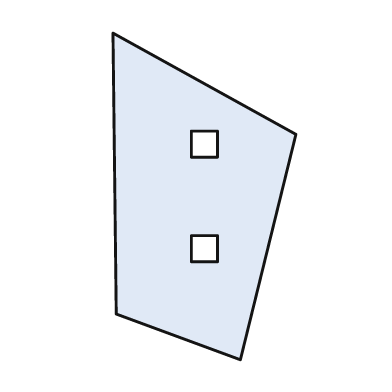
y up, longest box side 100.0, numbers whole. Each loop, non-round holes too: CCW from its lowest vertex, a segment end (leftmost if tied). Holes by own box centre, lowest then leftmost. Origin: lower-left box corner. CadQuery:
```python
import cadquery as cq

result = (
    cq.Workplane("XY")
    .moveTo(39.0, 0.0)
    .lineTo(56.0, 69.0)
    .lineTo(0.0, 100.0)
    .lineTo(1.0, 14.0)
    .close()
    .moveTo(24.0, 30.0)
    .lineTo(32.0, 30.0)
    .lineTo(32.0, 38.0)
    .lineTo(24.0, 38.0)
    .close()
    .moveTo(24.0, 62.0)
    .lineTo(32.0, 62.0)
    .lineTo(32.0, 70.0)
    .lineTo(24.0, 70.0)
    .close()
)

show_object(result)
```